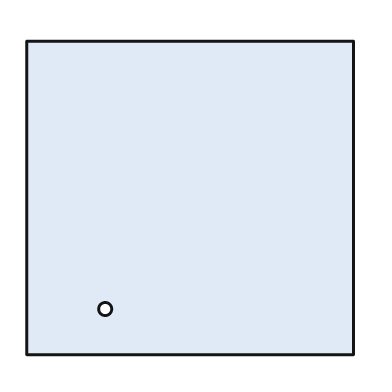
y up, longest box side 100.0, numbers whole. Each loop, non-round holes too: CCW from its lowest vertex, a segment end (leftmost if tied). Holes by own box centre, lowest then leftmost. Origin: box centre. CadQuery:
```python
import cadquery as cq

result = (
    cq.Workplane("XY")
    .moveTo(-50.0, -48.0)
    .lineTo(50.0, -48.0)
    .lineTo(50.0, 48.0)
    .lineTo(-50.0, 48.0)
    .close()
    .moveTo(-26.0, -34.0)
    .circle(2.0)
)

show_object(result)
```